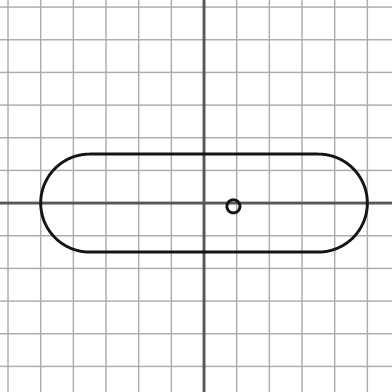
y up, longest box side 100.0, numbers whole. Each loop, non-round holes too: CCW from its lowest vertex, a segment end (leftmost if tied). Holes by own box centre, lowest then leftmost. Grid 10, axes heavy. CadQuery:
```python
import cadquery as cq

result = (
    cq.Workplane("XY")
    .moveTo(-35.0, -15.0)
    .lineTo(35.0, -15.0)
    .threePointArc((50.0, 0.0), (35.0, 15.0))
    .lineTo(-35.0, 15.0)
    .threePointArc((-50.0, 0.0), (-35.0, -15.0))
    .close()
    .moveTo(9.0, -1.0)
    .circle(2.0)
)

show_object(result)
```